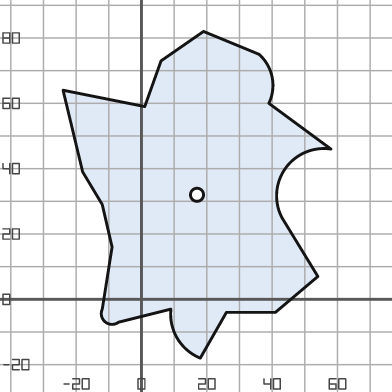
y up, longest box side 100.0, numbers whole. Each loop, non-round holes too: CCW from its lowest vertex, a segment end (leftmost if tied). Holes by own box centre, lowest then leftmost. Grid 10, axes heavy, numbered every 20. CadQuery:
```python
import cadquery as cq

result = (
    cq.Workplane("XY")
    .moveTo(18.0, -18.0)
    .lineTo(26.0, -4.0)
    .lineTo(41.0, -4.0)
    .lineTo(54.0, 7.0)
    .lineTo(43.0, 25.0)
    .threePointArc((44.0, 40.0), (58.0, 46.0))
    .lineTo(39.0, 60.0)
    .threePointArc((40.0, 68.0), (36.0, 75.0))
    .lineTo(19.0, 82.0)
    .lineTo(6.0, 73.0)
    .lineTo(1.0, 59.0)
    .lineTo(-24.0, 64.0)
    .lineTo(-18.0, 39.0)
    .lineTo(-12.0, 29.0)
    .lineTo(-9.0, 16.0)
    .lineTo(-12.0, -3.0)
    .threePointArc((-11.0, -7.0), (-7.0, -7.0))
    .lineTo(9.0, -3.0)
    .threePointArc((11.0, -12.0), (18.0, -18.0))
    .close()
    .moveTo(17.0, 32.0)
    .circle(2.0)
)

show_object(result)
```